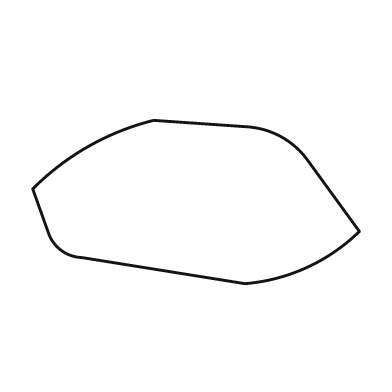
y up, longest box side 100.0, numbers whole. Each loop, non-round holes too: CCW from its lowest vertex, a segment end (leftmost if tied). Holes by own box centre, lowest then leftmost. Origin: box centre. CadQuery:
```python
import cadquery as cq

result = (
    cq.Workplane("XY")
    .moveTo(15.0, -25.0)
    .threePointArc((34.0, -20.0), (50.0, -9.0))
    .lineTo(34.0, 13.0)
    .threePointArc((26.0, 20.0), (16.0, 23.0))
    .lineTo(-13.0, 25.0)
    .threePointArc((-33.0, 17.0), (-50.0, 4.0))
    .lineTo(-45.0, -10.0)
    .threePointArc((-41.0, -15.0), (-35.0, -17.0))
    .close()
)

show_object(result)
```